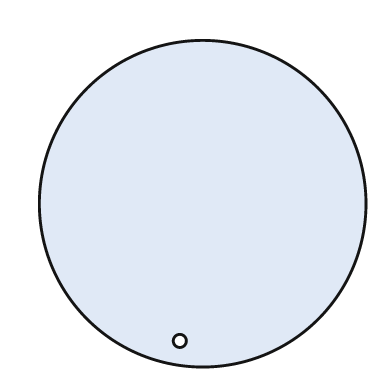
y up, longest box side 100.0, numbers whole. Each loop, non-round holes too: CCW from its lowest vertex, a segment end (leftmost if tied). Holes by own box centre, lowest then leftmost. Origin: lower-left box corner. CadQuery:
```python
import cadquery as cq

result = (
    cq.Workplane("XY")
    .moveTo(50.0, 50.0)
    .circle(50.0)
    .moveTo(43.0, 8.0)
    .circle(2.0)
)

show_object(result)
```